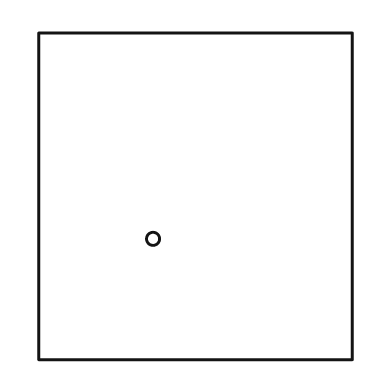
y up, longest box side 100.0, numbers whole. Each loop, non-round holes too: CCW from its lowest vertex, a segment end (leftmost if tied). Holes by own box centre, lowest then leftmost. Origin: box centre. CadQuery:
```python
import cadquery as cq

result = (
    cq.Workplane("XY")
    .moveTo(-48.0, -50.0)
    .lineTo(48.0, -50.0)
    .lineTo(48.0, 50.0)
    .lineTo(-48.0, 50.0)
    .close()
    .moveTo(-13.0, -13.0)
    .circle(2.0)
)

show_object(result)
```